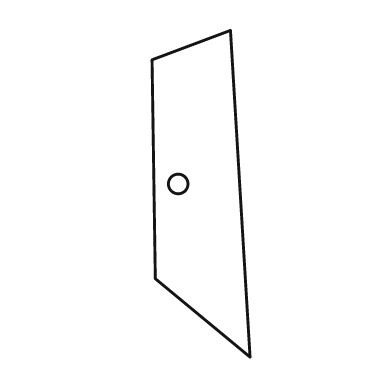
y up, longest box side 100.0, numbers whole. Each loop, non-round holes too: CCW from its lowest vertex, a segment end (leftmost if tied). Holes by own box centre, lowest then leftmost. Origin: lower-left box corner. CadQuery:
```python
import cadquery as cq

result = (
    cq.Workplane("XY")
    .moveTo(30.0, 0.0)
    .lineTo(24.0, 100.0)
    .lineTo(0.0, 91.0)
    .lineTo(1.0, 24.0)
    .close()
    .moveTo(8.0, 53.0)
    .circle(3.0)
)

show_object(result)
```